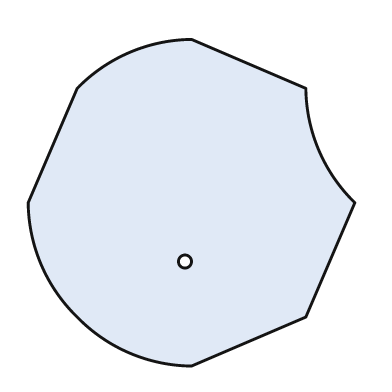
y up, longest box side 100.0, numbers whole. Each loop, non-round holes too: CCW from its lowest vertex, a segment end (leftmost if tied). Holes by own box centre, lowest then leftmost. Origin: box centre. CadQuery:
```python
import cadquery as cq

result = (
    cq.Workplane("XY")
    .moveTo(0.0, -50.0)
    .lineTo(35.0, -35.0)
    .lineTo(50.0, 0.0)
    .threePointArc((39.0, 16.0), (35.0, 35.0))
    .lineTo(0.0, 50.0)
    .threePointArc((-19.0, 46.0), (-35.0, 35.0))
    .lineTo(-50.0, 0.0)
    .threePointArc((-46.0, -19.0), (-35.0, -35.0))
    .threePointArc((-19.0, -46.0), (0.0, -50.0))
    .close()
    .moveTo(-2.0, -18.0)
    .circle(2.0)
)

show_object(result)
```